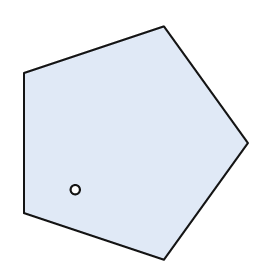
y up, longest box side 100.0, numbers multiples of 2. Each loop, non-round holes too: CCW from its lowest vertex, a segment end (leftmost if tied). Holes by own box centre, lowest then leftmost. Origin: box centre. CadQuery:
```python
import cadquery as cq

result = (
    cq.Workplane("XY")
    .moveTo(12.0, -50.0)
    .lineTo(48.0, 0.0)
    .lineTo(12.0, 50.0)
    .lineTo(-48.0, 30.0)
    .lineTo(-48.0, -30.0)
    .close()
    .moveTo(-26.0, -20.0)
    .circle(2.0)
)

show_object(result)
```